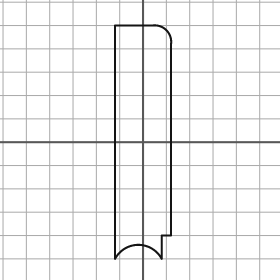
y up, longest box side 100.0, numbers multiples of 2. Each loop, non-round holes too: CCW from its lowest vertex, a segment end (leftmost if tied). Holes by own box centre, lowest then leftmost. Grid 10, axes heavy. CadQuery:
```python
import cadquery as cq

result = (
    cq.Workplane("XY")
    .moveTo(-12.0, -50.0)
    .threePointArc((-2.0, -44.0), (8.0, -50.0))
    .lineTo(8.0, -40.0)
    .lineTo(12.0, -40.0)
    .lineTo(12.0, 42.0)
    .threePointArc((10.0, 48.0), (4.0, 50.0))
    .lineTo(-12.0, 50.0)
    .close()
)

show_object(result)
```